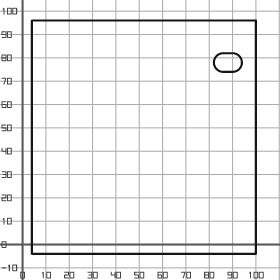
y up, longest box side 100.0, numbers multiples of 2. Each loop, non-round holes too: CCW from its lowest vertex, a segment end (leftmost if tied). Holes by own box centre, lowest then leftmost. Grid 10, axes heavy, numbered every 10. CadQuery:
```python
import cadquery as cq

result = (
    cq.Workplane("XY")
    .moveTo(4.0, -4.0)
    .lineTo(100.0, -4.0)
    .lineTo(100.0, 96.0)
    .lineTo(4.0, 96.0)
    .close()
    .moveTo(86.0, 74.0)
    .lineTo(90.0, 74.0)
    .threePointArc((94.0, 78.0), (90.0, 82.0))
    .lineTo(86.0, 82.0)
    .threePointArc((82.0, 78.0), (86.0, 74.0))
    .close()
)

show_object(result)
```